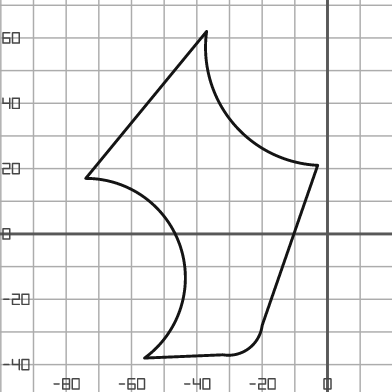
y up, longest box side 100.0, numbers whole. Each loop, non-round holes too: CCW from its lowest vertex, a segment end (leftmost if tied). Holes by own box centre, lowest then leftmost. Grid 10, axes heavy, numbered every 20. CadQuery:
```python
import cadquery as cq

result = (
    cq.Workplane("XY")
    .moveTo(-56.0, -38.0)
    .lineTo(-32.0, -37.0)
    .threePointArc((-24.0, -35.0), (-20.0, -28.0))
    .lineTo(-3.0, 21.0)
    .threePointArc((-29.0, 34.0), (-37.0, 62.0))
    .lineTo(-74.0, 17.0)
    .threePointArc((-45.0, -4.0), (-56.0, -38.0))
    .close()
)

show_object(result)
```